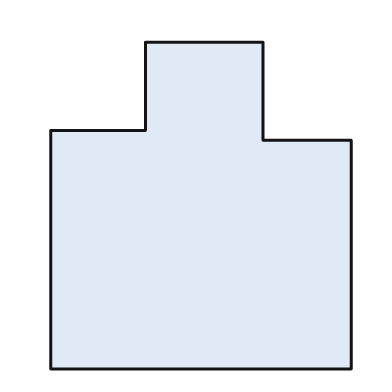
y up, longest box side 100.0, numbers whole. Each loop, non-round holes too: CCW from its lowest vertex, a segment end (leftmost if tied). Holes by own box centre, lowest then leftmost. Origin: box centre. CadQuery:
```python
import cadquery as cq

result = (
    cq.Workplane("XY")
    .moveTo(-46.0, -50.0)
    .lineTo(46.0, -50.0)
    .lineTo(46.0, 20.0)
    .lineTo(19.0, 20.0)
    .lineTo(19.0, 50.0)
    .lineTo(-17.0, 50.0)
    .lineTo(-17.0, 23.0)
    .lineTo(-46.0, 23.0)
    .close()
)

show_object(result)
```